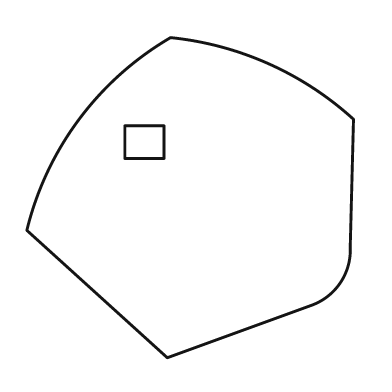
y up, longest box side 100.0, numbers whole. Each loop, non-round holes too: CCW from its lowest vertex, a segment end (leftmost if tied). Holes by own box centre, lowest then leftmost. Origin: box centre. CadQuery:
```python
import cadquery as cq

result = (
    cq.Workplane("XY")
    .moveTo(-7.0, -49.0)
    .lineTo(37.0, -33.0)
    .threePointArc((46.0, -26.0), (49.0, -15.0))
    .lineTo(50.0, 24.0)
    .threePointArc((24.0, 41.0), (-6.0, 49.0))
    .threePointArc((-34.0, 24.0), (-50.0, -10.0))
    .close()
    .moveTo(-20.0, 12.0)
    .lineTo(-8.0, 12.0)
    .lineTo(-8.0, 22.0)
    .lineTo(-20.0, 22.0)
    .close()
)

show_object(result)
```